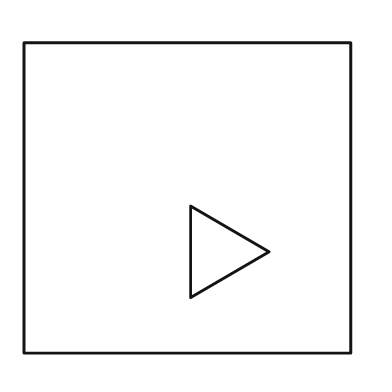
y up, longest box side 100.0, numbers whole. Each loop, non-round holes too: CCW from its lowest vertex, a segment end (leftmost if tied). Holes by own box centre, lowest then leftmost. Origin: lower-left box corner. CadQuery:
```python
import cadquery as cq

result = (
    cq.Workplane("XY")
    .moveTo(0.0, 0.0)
    .lineTo(100.0, 0.0)
    .lineTo(100.0, 95.0)
    .lineTo(0.0, 95.0)
    .close()
    .moveTo(51.0, 17.0)
    .lineTo(75.0, 31.0)
    .lineTo(51.0, 45.0)
    .close()
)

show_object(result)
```